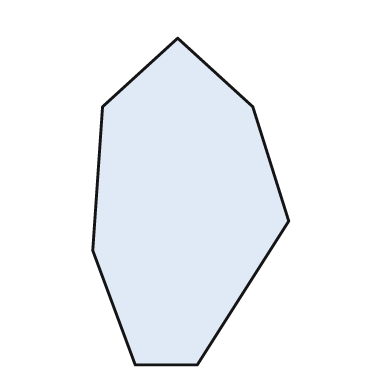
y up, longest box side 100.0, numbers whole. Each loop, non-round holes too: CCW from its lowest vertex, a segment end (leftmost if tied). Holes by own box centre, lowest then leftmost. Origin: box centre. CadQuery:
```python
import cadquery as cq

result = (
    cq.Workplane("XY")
    .moveTo(-17.0, -50.0)
    .lineTo(2.0, -50.0)
    .lineTo(30.0, -6.0)
    .lineTo(19.0, 29.0)
    .lineTo(-4.0, 50.0)
    .lineTo(-27.0, 29.0)
    .lineTo(-30.0, -15.0)
    .close()
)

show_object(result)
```